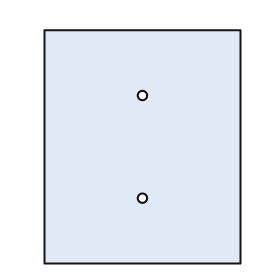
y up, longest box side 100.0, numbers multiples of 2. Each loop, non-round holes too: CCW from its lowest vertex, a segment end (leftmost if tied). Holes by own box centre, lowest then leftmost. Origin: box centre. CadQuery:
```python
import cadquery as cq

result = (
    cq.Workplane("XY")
    .moveTo(-42.0, -50.0)
    .lineTo(42.0, -50.0)
    .lineTo(42.0, 50.0)
    .lineTo(-42.0, 50.0)
    .close()
    .moveTo(0.0, -22.0)
    .circle(2.0)
    .moveTo(0.0, 22.0)
    .circle(2.0)
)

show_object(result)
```